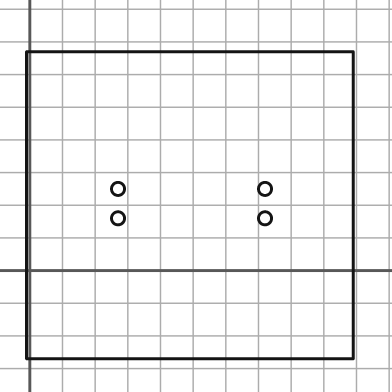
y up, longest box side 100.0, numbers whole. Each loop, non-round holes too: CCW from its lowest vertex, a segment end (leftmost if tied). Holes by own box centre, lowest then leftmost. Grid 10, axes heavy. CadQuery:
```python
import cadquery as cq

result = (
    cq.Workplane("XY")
    .moveTo(-1.0, -27.0)
    .lineTo(99.0, -27.0)
    .lineTo(99.0, 67.0)
    .lineTo(-1.0, 67.0)
    .close()
    .moveTo(27.0, 16.0)
    .circle(2.0)
    .moveTo(72.0, 16.0)
    .circle(2.0)
    .moveTo(27.0, 25.0)
    .circle(2.0)
    .moveTo(72.0, 25.0)
    .circle(2.0)
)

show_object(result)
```